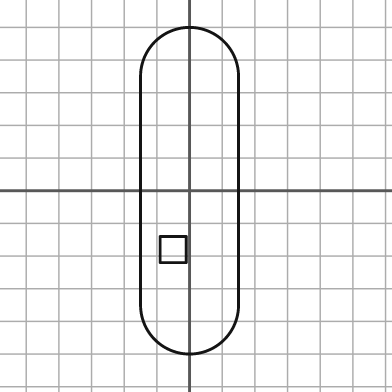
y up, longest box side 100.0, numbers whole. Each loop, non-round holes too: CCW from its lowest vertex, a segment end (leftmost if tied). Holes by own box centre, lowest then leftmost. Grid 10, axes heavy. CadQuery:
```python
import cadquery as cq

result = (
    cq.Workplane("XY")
    .moveTo(-15.0, -35.0)
    .threePointArc((0.0, -50.0), (15.0, -35.0))
    .lineTo(15.0, 35.0)
    .threePointArc((0.0, 50.0), (-15.0, 35.0))
    .close()
    .moveTo(-9.0, -22.0)
    .lineTo(-1.0, -22.0)
    .lineTo(-1.0, -14.0)
    .lineTo(-9.0, -14.0)
    .close()
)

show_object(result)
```